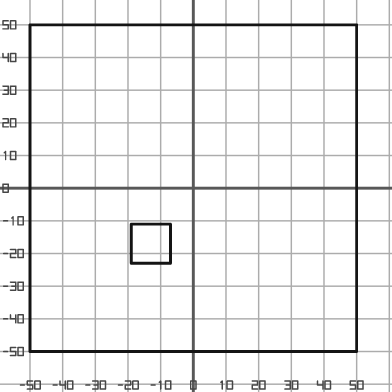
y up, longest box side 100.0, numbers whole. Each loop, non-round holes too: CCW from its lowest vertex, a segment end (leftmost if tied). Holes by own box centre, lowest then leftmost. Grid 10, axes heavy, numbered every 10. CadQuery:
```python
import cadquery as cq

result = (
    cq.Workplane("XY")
    .moveTo(-50.0, -50.0)
    .lineTo(50.0, -50.0)
    .lineTo(50.0, 50.0)
    .lineTo(-50.0, 50.0)
    .close()
    .moveTo(-19.0, -23.0)
    .lineTo(-7.0, -23.0)
    .lineTo(-7.0, -11.0)
    .lineTo(-19.0, -11.0)
    .close()
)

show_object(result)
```